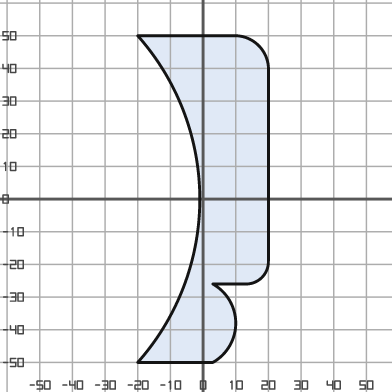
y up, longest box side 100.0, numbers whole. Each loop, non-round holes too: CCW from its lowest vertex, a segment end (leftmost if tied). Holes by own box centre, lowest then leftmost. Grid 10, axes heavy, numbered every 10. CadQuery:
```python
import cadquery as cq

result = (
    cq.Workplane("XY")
    .moveTo(-20.0, -50.0)
    .lineTo(3.0, -50.0)
    .threePointArc((10.0, -38.0), (3.0, -26.0))
    .lineTo(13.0, -26.0)
    .threePointArc((18.0, -24.0), (20.0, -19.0))
    .lineTo(20.0, 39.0)
    .threePointArc((17.0, 47.0), (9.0, 50.0))
    .lineTo(-20.0, 50.0)
    .threePointArc((-1.0, 0.0), (-20.0, -50.0))
    .close()
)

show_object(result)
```